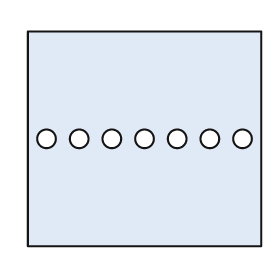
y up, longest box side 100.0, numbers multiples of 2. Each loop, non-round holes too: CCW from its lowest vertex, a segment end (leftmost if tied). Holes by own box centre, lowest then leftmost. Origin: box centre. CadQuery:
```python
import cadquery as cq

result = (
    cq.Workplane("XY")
    .moveTo(-50.0, -46.0)
    .lineTo(50.0, -46.0)
    .lineTo(50.0, 46.0)
    .lineTo(-50.0, 46.0)
    .close()
    .moveTo(-42.0, 0.0)
    .circle(4.0)
    .moveTo(-28.0, 0.0)
    .circle(4.0)
    .moveTo(-14.0, 0.0)
    .circle(4.0)
    .moveTo(0.0, 0.0)
    .circle(4.0)
    .moveTo(14.0, 0.0)
    .circle(4.0)
    .moveTo(28.0, 0.0)
    .circle(4.0)
    .moveTo(42.0, 0.0)
    .circle(4.0)
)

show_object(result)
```